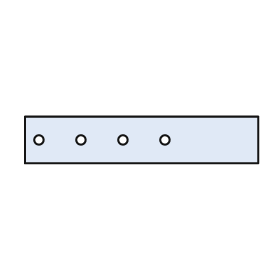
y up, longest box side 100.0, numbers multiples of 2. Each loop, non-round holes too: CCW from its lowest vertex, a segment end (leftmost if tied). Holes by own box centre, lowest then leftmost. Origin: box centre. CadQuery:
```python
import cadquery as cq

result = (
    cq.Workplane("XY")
    .moveTo(-50.0, -10.0)
    .lineTo(50.0, -10.0)
    .lineTo(50.0, 10.0)
    .lineTo(-50.0, 10.0)
    .close()
    .moveTo(-44.0, 0.0)
    .circle(2.0)
    .moveTo(-26.0, 0.0)
    .circle(2.0)
    .moveTo(-8.0, 0.0)
    .circle(2.0)
    .moveTo(10.0, 0.0)
    .circle(2.0)
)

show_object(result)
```